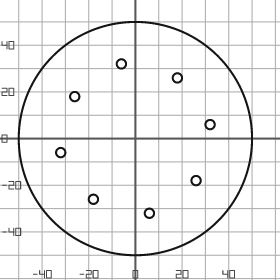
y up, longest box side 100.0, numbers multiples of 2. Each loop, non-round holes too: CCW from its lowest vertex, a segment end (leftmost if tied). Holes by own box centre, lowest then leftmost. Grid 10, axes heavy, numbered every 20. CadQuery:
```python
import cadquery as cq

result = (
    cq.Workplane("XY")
    .moveTo(0.0, 0.0)
    .circle(50.0)
    .moveTo(6.0, -32.0)
    .circle(2.0)
    .moveTo(-18.0, -26.0)
    .circle(2.0)
    .moveTo(26.0, -18.0)
    .circle(2.0)
    .moveTo(-32.0, -6.0)
    .circle(2.0)
    .moveTo(32.0, 6.0)
    .circle(2.0)
    .moveTo(-26.0, 18.0)
    .circle(2.0)
    .moveTo(18.0, 26.0)
    .circle(2.0)
    .moveTo(-6.0, 32.0)
    .circle(2.0)
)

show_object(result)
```